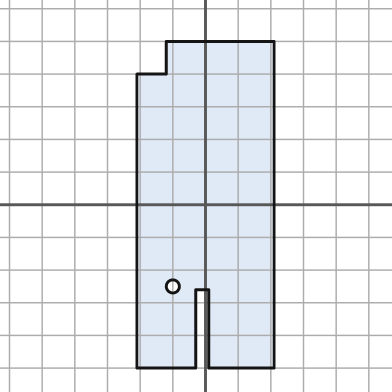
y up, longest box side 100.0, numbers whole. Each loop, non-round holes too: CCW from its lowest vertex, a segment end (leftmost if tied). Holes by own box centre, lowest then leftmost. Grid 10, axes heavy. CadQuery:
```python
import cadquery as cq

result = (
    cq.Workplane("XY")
    .moveTo(-21.0, -50.0)
    .lineTo(-3.0, -50.0)
    .lineTo(-3.0, -26.0)
    .lineTo(1.0, -26.0)
    .lineTo(1.0, -50.0)
    .lineTo(21.0, -50.0)
    .lineTo(21.0, 50.0)
    .lineTo(-12.0, 50.0)
    .lineTo(-12.0, 40.0)
    .lineTo(-21.0, 40.0)
    .close()
    .moveTo(-10.0, -25.0)
    .circle(2.0)
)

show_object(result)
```